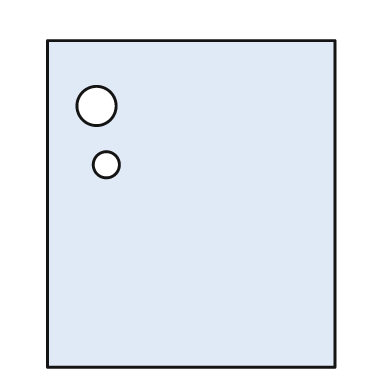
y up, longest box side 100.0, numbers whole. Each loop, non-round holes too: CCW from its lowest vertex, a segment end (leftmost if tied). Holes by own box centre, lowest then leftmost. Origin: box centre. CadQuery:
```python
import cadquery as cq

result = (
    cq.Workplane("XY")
    .moveTo(-44.0, -50.0)
    .lineTo(44.0, -50.0)
    .lineTo(44.0, 50.0)
    .lineTo(-44.0, 50.0)
    .close()
    .moveTo(-26.0, 12.0)
    .circle(4.0)
    .moveTo(-29.0, 30.0)
    .circle(6.0)
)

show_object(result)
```